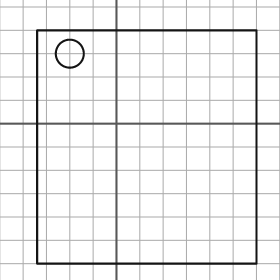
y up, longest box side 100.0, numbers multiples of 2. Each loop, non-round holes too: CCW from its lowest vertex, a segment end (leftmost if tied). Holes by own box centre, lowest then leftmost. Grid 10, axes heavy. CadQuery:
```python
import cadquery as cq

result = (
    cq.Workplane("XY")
    .moveTo(-34.0, -60.0)
    .lineTo(60.0, -60.0)
    .lineTo(60.0, 40.0)
    .lineTo(-34.0, 40.0)
    .close()
    .moveTo(-20.0, 30.0)
    .circle(6.0)
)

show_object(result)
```